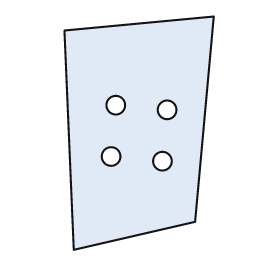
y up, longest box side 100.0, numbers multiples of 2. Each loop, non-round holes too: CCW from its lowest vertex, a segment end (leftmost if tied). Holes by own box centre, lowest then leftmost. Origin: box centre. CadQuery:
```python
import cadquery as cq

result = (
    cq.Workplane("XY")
    .moveTo(-28.0, -50.0)
    .lineTo(24.0, -38.0)
    .lineTo(32.0, 50.0)
    .lineTo(-32.0, 44.0)
    .close()
    .moveTo(10.0, -12.0)
    .circle(4.0)
    .moveTo(-12.0, -10.0)
    .circle(4.0)
    .moveTo(12.0, 10.0)
    .circle(4.0)
    .moveTo(-10.0, 12.0)
    .circle(4.0)
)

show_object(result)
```